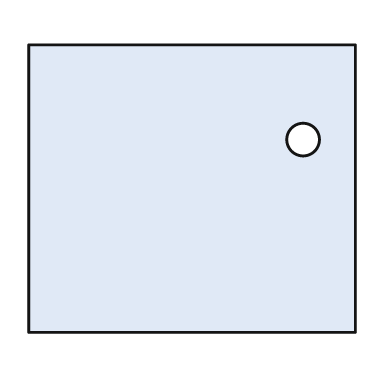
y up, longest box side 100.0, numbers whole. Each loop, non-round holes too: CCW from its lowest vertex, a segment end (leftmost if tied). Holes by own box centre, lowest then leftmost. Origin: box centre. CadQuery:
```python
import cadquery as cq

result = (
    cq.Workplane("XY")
    .moveTo(-50.0, -44.0)
    .lineTo(50.0, -44.0)
    .lineTo(50.0, 44.0)
    .lineTo(-50.0, 44.0)
    .close()
    .moveTo(34.0, 15.0)
    .circle(5.0)
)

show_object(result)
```